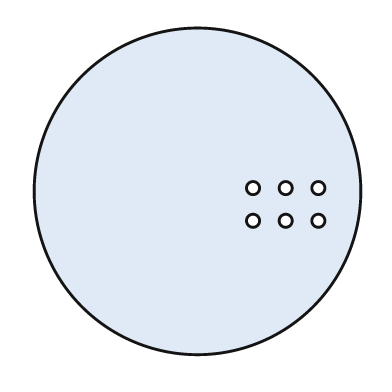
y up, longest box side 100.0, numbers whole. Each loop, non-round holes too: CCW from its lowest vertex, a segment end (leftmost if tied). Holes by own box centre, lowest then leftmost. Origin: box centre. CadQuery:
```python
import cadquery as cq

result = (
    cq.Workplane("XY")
    .moveTo(0.0, 0.0)
    .circle(50.0)
    .moveTo(17.0, -9.0)
    .circle(2.0)
    .moveTo(27.0, -9.0)
    .circle(2.0)
    .moveTo(37.0, -9.0)
    .circle(2.0)
    .moveTo(17.0, 1.0)
    .circle(2.0)
    .moveTo(27.0, 1.0)
    .circle(2.0)
    .moveTo(37.0, 1.0)
    .circle(2.0)
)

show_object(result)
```